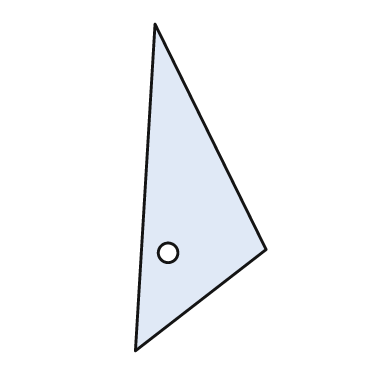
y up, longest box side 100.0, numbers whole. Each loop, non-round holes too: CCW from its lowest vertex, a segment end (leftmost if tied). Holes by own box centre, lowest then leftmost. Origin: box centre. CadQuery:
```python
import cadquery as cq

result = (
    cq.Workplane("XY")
    .moveTo(-20.0, -50.0)
    .lineTo(20.0, -19.0)
    .lineTo(-14.0, 50.0)
    .close()
    .moveTo(-10.0, -20.0)
    .circle(3.0)
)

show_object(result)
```